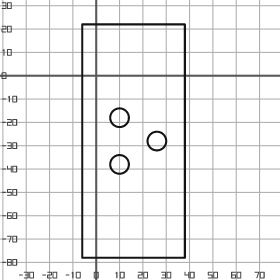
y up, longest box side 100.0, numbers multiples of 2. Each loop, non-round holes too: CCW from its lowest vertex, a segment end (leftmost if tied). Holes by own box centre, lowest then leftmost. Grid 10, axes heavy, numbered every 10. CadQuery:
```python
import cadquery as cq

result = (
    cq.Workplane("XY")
    .moveTo(-6.0, -78.0)
    .lineTo(38.0, -78.0)
    .lineTo(38.0, 22.0)
    .lineTo(-6.0, 22.0)
    .close()
    .moveTo(10.0, -38.0)
    .circle(4.0)
    .moveTo(26.0, -28.0)
    .circle(4.0)
    .moveTo(10.0, -18.0)
    .circle(4.0)
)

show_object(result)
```